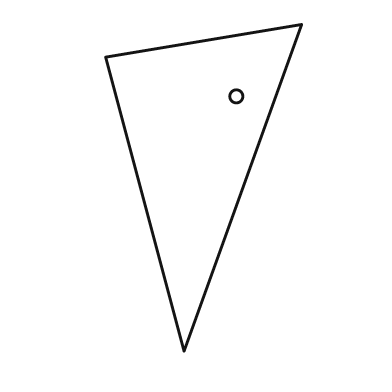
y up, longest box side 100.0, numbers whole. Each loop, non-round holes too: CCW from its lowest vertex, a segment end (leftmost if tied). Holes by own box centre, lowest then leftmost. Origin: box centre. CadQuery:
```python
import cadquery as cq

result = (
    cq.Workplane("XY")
    .moveTo(-6.0, -50.0)
    .lineTo(30.0, 50.0)
    .lineTo(-30.0, 40.0)
    .close()
    .moveTo(10.0, 28.0)
    .circle(2.0)
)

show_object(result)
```